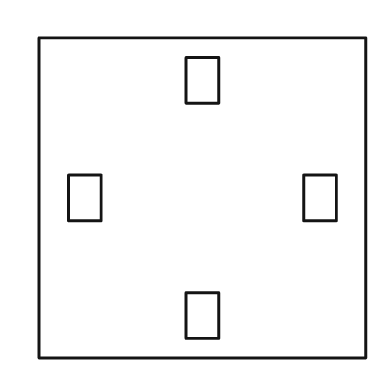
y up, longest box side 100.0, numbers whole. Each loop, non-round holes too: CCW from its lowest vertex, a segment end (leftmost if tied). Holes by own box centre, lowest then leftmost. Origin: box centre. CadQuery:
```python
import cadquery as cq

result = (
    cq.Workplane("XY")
    .moveTo(-50.0, -49.0)
    .lineTo(50.0, -49.0)
    .lineTo(50.0, 49.0)
    .lineTo(-50.0, 49.0)
    .close()
    .moveTo(-5.0, -43.0)
    .lineTo(5.0, -43.0)
    .lineTo(5.0, -29.0)
    .lineTo(-5.0, -29.0)
    .close()
    .moveTo(-41.0, -7.0)
    .lineTo(-31.0, -7.0)
    .lineTo(-31.0, 7.0)
    .lineTo(-41.0, 7.0)
    .close()
    .moveTo(31.0, -7.0)
    .lineTo(41.0, -7.0)
    .lineTo(41.0, 7.0)
    .lineTo(31.0, 7.0)
    .close()
    .moveTo(-5.0, 29.0)
    .lineTo(5.0, 29.0)
    .lineTo(5.0, 43.0)
    .lineTo(-5.0, 43.0)
    .close()
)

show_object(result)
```